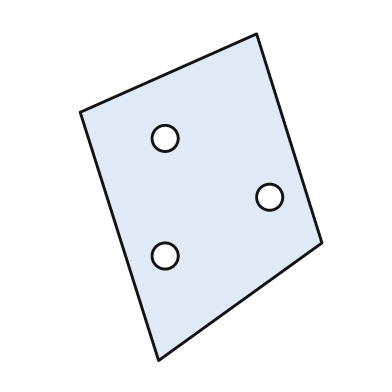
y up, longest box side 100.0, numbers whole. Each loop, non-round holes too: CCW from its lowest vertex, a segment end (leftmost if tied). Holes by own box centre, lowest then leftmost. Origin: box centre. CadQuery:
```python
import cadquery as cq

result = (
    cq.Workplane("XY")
    .moveTo(-13.0, -50.0)
    .lineTo(37.0, -14.0)
    .lineTo(17.0, 50.0)
    .lineTo(-37.0, 26.0)
    .close()
    .moveTo(-11.0, -18.0)
    .circle(4.0)
    .moveTo(21.0, 0.0)
    .circle(4.0)
    .moveTo(-11.0, 18.0)
    .circle(4.0)
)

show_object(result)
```